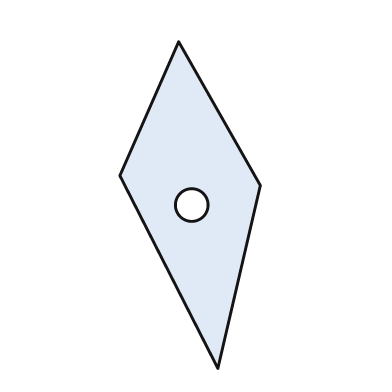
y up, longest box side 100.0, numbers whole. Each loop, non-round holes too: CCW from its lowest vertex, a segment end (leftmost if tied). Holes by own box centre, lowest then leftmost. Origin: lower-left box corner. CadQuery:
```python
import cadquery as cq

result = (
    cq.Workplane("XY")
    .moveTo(30.0, 0.0)
    .lineTo(43.0, 56.0)
    .lineTo(18.0, 100.0)
    .lineTo(0.0, 59.0)
    .close()
    .moveTo(22.0, 50.0)
    .circle(5.0)
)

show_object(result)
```